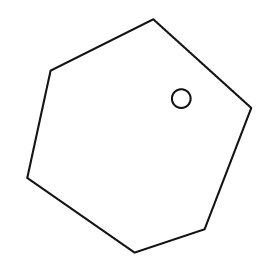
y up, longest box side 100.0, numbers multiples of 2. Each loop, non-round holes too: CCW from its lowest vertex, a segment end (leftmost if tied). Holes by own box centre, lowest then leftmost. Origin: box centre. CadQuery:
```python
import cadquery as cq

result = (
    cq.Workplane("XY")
    .moveTo(-2.0, -50.0)
    .lineTo(28.0, -40.0)
    .lineTo(48.0, 12.0)
    .lineTo(6.0, 50.0)
    .lineTo(-38.0, 28.0)
    .lineTo(-48.0, -18.0)
    .close()
    .moveTo(18.0, 16.0)
    .circle(4.0)
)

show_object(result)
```